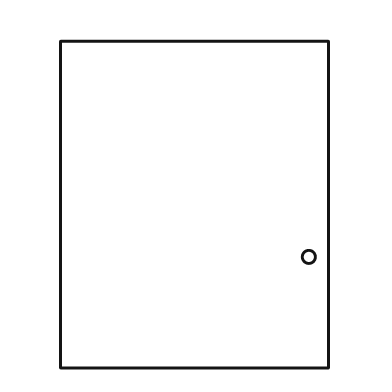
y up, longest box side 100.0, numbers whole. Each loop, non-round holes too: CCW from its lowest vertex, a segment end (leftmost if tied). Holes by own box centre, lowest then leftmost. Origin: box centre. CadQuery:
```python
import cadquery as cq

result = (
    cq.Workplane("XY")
    .moveTo(-41.0, -50.0)
    .lineTo(41.0, -50.0)
    .lineTo(41.0, 50.0)
    .lineTo(-41.0, 50.0)
    .close()
    .moveTo(35.0, -16.0)
    .circle(2.0)
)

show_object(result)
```